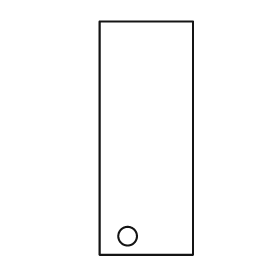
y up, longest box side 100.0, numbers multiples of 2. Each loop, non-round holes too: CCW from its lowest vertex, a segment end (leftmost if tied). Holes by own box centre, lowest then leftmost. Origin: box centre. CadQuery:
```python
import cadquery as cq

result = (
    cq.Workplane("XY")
    .moveTo(-20.0, -50.0)
    .lineTo(20.0, -50.0)
    .lineTo(20.0, 50.0)
    .lineTo(-20.0, 50.0)
    .close()
    .moveTo(-8.0, -42.0)
    .circle(4.0)
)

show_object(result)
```